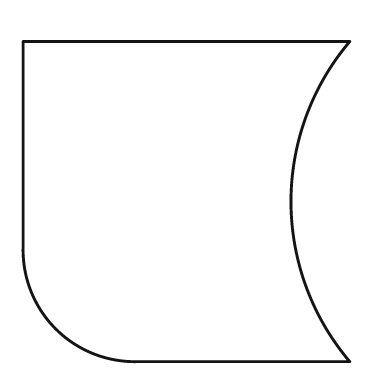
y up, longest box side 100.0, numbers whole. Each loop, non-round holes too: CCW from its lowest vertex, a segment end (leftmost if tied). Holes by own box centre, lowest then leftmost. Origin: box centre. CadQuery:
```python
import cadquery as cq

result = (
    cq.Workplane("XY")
    .moveTo(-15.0, -49.0)
    .lineTo(50.0, -49.0)
    .threePointArc((32.0, 0.0), (50.0, 49.0))
    .lineTo(-50.0, 49.0)
    .lineTo(-50.0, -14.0)
    .threePointArc((-40.0, -39.0), (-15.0, -49.0))
    .close()
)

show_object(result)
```